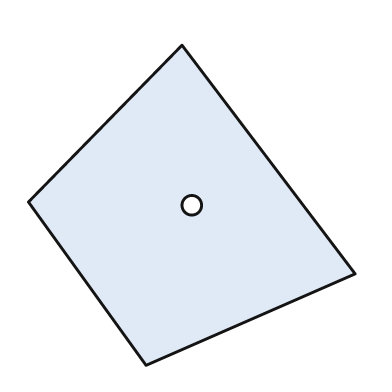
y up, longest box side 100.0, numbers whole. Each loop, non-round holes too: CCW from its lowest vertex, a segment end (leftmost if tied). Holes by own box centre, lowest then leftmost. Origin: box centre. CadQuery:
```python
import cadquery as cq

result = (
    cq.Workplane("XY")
    .moveTo(-14.0, -49.0)
    .lineTo(50.0, -21.0)
    .lineTo(-3.0, 49.0)
    .lineTo(-50.0, 1.0)
    .close()
    .moveTo(0.0, 0.0)
    .circle(3.0)
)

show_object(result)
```